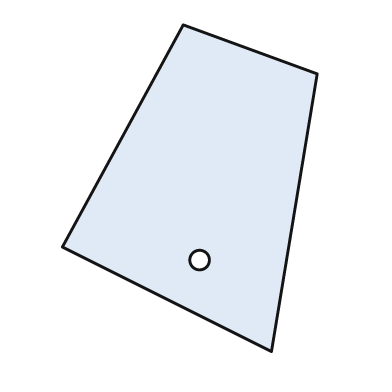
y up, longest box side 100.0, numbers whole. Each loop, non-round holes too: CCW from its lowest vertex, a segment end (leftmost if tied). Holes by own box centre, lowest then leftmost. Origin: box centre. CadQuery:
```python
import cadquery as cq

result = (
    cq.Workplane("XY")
    .moveTo(25.0, -50.0)
    .lineTo(39.0, 35.0)
    .lineTo(-2.0, 50.0)
    .lineTo(-39.0, -18.0)
    .close()
    .moveTo(3.0, -22.0)
    .circle(3.0)
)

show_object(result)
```